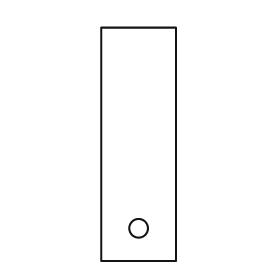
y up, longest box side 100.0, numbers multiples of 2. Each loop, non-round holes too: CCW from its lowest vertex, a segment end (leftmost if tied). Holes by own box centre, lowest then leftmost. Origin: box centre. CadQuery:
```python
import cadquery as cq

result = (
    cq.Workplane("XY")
    .moveTo(-16.0, -50.0)
    .lineTo(16.0, -50.0)
    .lineTo(16.0, 50.0)
    .lineTo(-16.0, 50.0)
    .close()
    .moveTo(0.0, -36.0)
    .circle(4.0)
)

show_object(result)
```